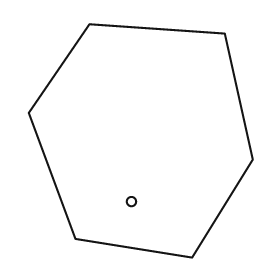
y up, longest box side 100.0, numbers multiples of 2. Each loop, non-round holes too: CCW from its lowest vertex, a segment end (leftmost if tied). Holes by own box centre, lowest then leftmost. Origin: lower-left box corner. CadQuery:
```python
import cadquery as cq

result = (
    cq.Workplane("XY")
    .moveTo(70.0, 0.0)
    .lineTo(96.0, 42.0)
    .lineTo(84.0, 96.0)
    .lineTo(26.0, 100.0)
    .lineTo(0.0, 62.0)
    .lineTo(20.0, 8.0)
    .close()
    .moveTo(44.0, 24.0)
    .circle(2.0)
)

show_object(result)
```